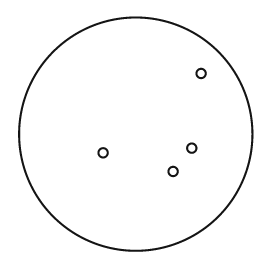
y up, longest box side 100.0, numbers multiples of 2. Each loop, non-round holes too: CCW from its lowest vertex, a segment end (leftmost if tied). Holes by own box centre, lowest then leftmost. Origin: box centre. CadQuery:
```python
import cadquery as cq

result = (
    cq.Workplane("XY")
    .moveTo(0.0, 0.0)
    .circle(50.0)
    .moveTo(16.0, -16.0)
    .circle(2.0)
    .moveTo(-14.0, -8.0)
    .circle(2.0)
    .moveTo(24.0, -6.0)
    .circle(2.0)
    .moveTo(28.0, 26.0)
    .circle(2.0)
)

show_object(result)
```